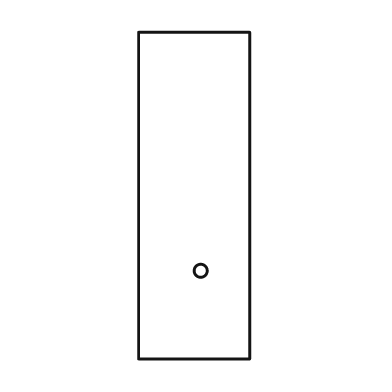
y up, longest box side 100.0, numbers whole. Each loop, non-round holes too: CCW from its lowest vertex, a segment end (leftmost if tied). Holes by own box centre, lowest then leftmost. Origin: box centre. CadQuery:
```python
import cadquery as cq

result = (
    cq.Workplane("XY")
    .moveTo(-17.0, -50.0)
    .lineTo(17.0, -50.0)
    .lineTo(17.0, 50.0)
    .lineTo(-17.0, 50.0)
    .close()
    .moveTo(2.0, -23.0)
    .circle(2.0)
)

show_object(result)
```